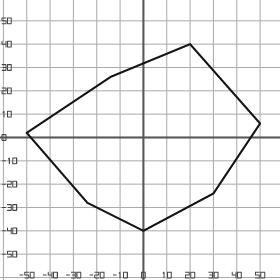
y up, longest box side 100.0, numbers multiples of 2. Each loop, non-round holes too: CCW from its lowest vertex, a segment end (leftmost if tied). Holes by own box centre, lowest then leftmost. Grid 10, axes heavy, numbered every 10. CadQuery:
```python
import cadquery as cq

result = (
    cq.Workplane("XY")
    .moveTo(0.0, -40.0)
    .lineTo(30.0, -24.0)
    .lineTo(50.0, 6.0)
    .lineTo(20.0, 40.0)
    .lineTo(-14.0, 26.0)
    .lineTo(-50.0, 2.0)
    .lineTo(-24.0, -28.0)
    .close()
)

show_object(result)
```